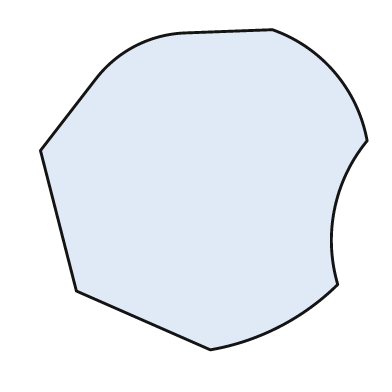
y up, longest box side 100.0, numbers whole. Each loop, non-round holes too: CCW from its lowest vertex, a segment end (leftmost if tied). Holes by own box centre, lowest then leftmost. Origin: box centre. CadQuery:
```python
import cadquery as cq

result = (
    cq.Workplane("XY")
    .moveTo(2.0, -49.0)
    .threePointArc((23.0, -42.0), (41.0, -29.0))
    .threePointArc((40.0, -6.0), (50.0, 15.0))
    .threePointArc((40.0, 36.0), (21.0, 49.0))
    .lineTo(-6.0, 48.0)
    .threePointArc((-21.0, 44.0), (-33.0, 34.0))
    .lineTo(-50.0, 12.0)
    .lineTo(-39.0, -31.0)
    .close()
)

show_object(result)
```